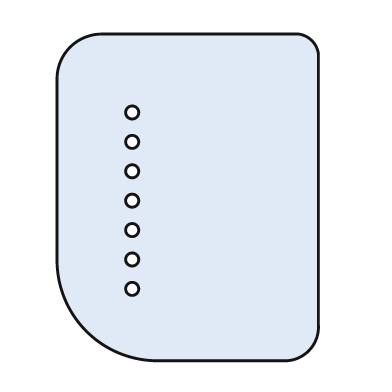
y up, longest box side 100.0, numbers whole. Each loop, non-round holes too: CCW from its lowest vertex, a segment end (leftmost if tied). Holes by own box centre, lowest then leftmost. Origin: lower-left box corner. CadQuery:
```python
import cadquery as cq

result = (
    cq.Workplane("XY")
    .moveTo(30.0, 0.0)
    .lineTo(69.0, 0.0)
    .threePointArc((77.0, 3.0), (80.0, 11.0))
    .lineTo(80.0, 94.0)
    .threePointArc((78.0, 98.0), (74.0, 100.0))
    .lineTo(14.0, 100.0)
    .threePointArc((4.0, 96.0), (0.0, 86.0))
    .lineTo(0.0, 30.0)
    .threePointArc((9.0, 9.0), (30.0, 0.0))
    .close()
    .moveTo(23.0, 22.0)
    .circle(2.0)
    .moveTo(23.0, 31.0)
    .circle(2.0)
    .moveTo(23.0, 40.0)
    .circle(2.0)
    .moveTo(23.0, 49.0)
    .circle(2.0)
    .moveTo(23.0, 58.0)
    .circle(2.0)
    .moveTo(23.0, 67.0)
    .circle(2.0)
    .moveTo(23.0, 76.0)
    .circle(2.0)
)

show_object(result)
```